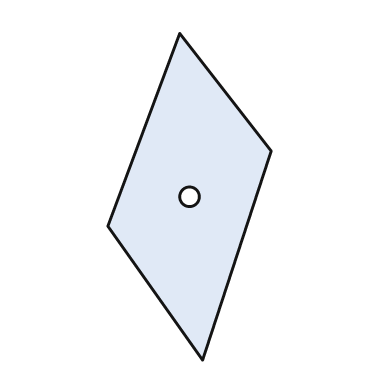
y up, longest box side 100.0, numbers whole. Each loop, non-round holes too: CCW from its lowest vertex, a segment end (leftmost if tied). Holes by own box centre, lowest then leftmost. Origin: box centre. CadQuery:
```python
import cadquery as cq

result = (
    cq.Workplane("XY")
    .moveTo(4.0, -50.0)
    .lineTo(25.0, 14.0)
    .lineTo(-3.0, 50.0)
    .lineTo(-25.0, -9.0)
    .close()
    .moveTo(0.0, 0.0)
    .circle(3.0)
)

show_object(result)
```